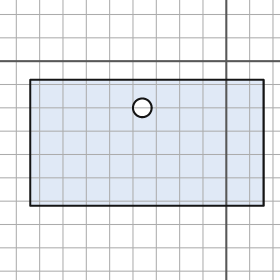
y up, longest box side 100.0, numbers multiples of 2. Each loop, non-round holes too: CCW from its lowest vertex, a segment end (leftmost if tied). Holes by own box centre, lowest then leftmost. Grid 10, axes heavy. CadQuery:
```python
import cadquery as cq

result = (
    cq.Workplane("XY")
    .moveTo(-84.0, -62.0)
    .lineTo(16.0, -62.0)
    .lineTo(16.0, -8.0)
    .lineTo(-84.0, -8.0)
    .close()
    .moveTo(-36.0, -20.0)
    .circle(4.0)
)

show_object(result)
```